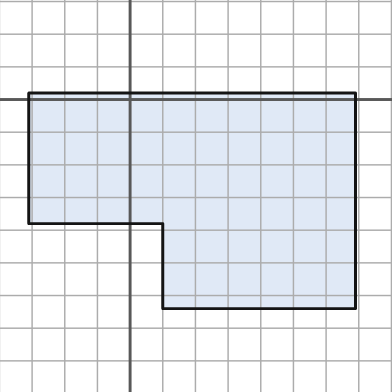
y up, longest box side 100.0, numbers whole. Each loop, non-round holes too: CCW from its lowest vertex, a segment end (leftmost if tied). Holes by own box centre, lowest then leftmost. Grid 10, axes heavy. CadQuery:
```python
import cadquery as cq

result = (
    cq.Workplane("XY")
    .moveTo(10.0, -64.0)
    .lineTo(69.0, -64.0)
    .lineTo(69.0, 2.0)
    .lineTo(-31.0, 2.0)
    .lineTo(-31.0, -38.0)
    .lineTo(10.0, -38.0)
    .close()
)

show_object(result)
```